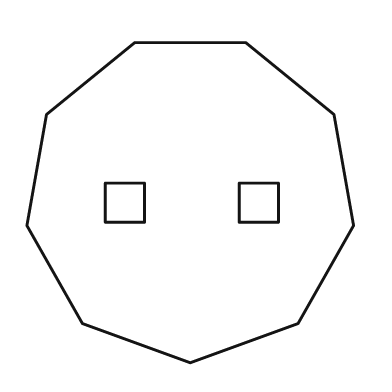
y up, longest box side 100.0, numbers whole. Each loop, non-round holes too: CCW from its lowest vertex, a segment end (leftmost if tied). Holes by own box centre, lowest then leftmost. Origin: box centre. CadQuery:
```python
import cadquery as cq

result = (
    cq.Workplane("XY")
    .moveTo(0.0, -49.0)
    .lineTo(33.0, -37.0)
    .lineTo(50.0, -7.0)
    .lineTo(44.0, 27.0)
    .lineTo(17.0, 49.0)
    .lineTo(-17.0, 49.0)
    .lineTo(-44.0, 27.0)
    .lineTo(-50.0, -7.0)
    .lineTo(-33.0, -37.0)
    .close()
    .moveTo(-26.0, -6.0)
    .lineTo(-14.0, -6.0)
    .lineTo(-14.0, 6.0)
    .lineTo(-26.0, 6.0)
    .close()
    .moveTo(15.0, -6.0)
    .lineTo(27.0, -6.0)
    .lineTo(27.0, 6.0)
    .lineTo(15.0, 6.0)
    .close()
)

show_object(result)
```